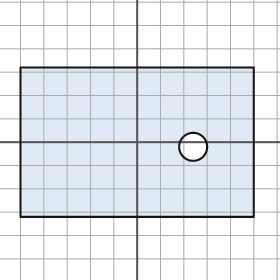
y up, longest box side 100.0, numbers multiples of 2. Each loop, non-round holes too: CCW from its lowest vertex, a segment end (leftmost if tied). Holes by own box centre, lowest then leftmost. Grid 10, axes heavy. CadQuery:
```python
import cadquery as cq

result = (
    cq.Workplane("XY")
    .moveTo(-50.0, -32.0)
    .lineTo(50.0, -32.0)
    .lineTo(50.0, 32.0)
    .lineTo(-50.0, 32.0)
    .close()
    .moveTo(24.0, -2.0)
    .circle(6.0)
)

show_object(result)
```